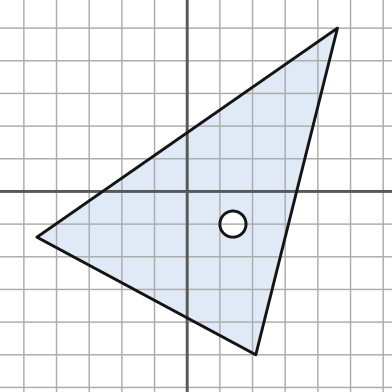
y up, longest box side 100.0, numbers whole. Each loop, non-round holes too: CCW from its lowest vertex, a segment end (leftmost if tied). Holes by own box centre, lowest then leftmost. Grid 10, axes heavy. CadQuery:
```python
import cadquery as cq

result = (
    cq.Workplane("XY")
    .moveTo(21.0, -50.0)
    .lineTo(46.0, 50.0)
    .lineTo(-46.0, -14.0)
    .close()
    .moveTo(14.0, -10.0)
    .circle(4.0)
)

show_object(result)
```